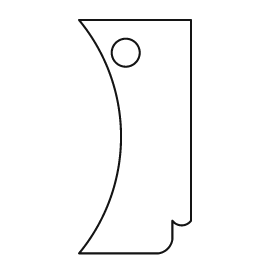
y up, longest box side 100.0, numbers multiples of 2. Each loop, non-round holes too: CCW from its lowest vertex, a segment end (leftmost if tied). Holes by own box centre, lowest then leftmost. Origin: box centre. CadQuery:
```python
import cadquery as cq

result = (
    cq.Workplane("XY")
    .moveTo(-24.0, -50.0)
    .lineTo(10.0, -50.0)
    .threePointArc((14.0, -48.0), (16.0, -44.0))
    .lineTo(16.0, -36.0)
    .threePointArc((20.0, -38.0), (24.0, -36.0))
    .lineTo(24.0, 50.0)
    .lineTo(-24.0, 50.0)
    .threePointArc((-6.0, 0.0), (-24.0, -50.0))
    .close()
    .moveTo(-4.0, 36.0)
    .circle(6.0)
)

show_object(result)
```